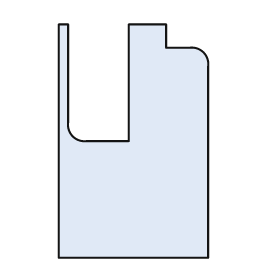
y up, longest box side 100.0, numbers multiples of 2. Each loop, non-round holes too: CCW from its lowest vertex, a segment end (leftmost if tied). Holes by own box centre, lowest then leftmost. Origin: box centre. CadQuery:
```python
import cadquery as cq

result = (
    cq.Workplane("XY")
    .moveTo(-32.0, -50.0)
    .lineTo(32.0, -50.0)
    .lineTo(32.0, 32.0)
    .threePointArc((30.0, 38.0), (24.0, 40.0))
    .lineTo(14.0, 40.0)
    .lineTo(14.0, 50.0)
    .lineTo(-2.0, 50.0)
    .lineTo(-2.0, 0.0)
    .lineTo(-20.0, 0.0)
    .threePointArc((-26.0, 2.0), (-28.0, 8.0))
    .lineTo(-28.0, 50.0)
    .lineTo(-32.0, 50.0)
    .close()
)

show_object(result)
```